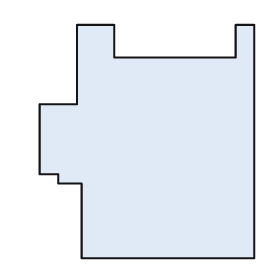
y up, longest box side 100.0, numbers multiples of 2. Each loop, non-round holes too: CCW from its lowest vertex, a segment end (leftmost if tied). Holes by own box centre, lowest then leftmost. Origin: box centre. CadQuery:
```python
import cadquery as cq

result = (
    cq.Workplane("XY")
    .moveTo(-28.0, -50.0)
    .lineTo(46.0, -50.0)
    .lineTo(46.0, 50.0)
    .lineTo(38.0, 50.0)
    .lineTo(38.0, 36.0)
    .lineTo(-14.0, 36.0)
    .lineTo(-14.0, 50.0)
    .lineTo(-30.0, 50.0)
    .lineTo(-30.0, 16.0)
    .lineTo(-46.0, 16.0)
    .lineTo(-46.0, -14.0)
    .lineTo(-38.0, -14.0)
    .lineTo(-38.0, -18.0)
    .lineTo(-28.0, -18.0)
    .close()
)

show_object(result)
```